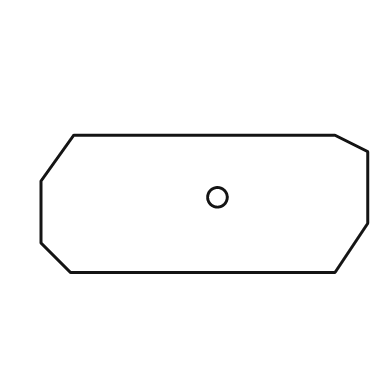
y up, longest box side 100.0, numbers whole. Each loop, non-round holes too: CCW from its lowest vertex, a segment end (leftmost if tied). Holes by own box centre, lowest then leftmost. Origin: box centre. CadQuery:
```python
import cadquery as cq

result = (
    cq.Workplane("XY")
    .moveTo(-41.0, -21.0)
    .lineTo(40.0, -21.0)
    .lineTo(50.0, -6.0)
    .lineTo(50.0, 16.0)
    .lineTo(40.0, 21.0)
    .lineTo(-40.0, 21.0)
    .lineTo(-50.0, 7.0)
    .lineTo(-50.0, -12.0)
    .close()
    .moveTo(4.0, 2.0)
    .circle(3.0)
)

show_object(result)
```